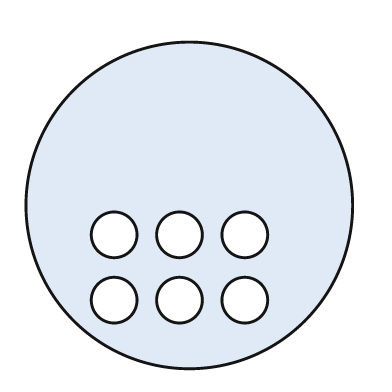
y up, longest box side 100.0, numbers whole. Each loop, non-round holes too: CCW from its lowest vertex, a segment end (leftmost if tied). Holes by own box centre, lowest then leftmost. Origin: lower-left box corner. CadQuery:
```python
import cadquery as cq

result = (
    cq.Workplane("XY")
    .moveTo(50.0, 50.0)
    .circle(50.0)
    .moveTo(27.0, 21.0)
    .circle(7.0)
    .moveTo(47.0, 21.0)
    .circle(7.0)
    .moveTo(67.0, 21.0)
    .circle(7.0)
    .moveTo(27.0, 41.0)
    .circle(7.0)
    .moveTo(47.0, 41.0)
    .circle(7.0)
    .moveTo(67.0, 41.0)
    .circle(7.0)
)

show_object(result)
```